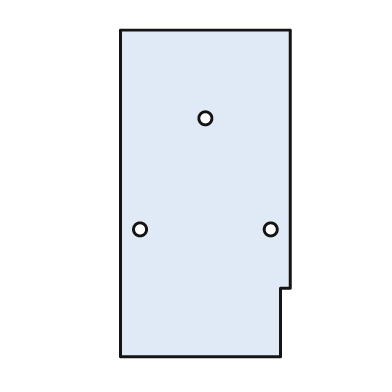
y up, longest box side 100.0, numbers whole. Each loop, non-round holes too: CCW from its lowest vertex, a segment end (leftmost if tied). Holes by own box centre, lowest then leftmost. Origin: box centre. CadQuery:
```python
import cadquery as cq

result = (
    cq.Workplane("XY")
    .moveTo(-26.0, -50.0)
    .lineTo(23.0, -50.0)
    .lineTo(23.0, -29.0)
    .lineTo(26.0, -29.0)
    .lineTo(26.0, 50.0)
    .lineTo(-26.0, 50.0)
    .close()
    .moveTo(-20.0, -11.0)
    .circle(2.0)
    .moveTo(20.0, -11.0)
    .circle(2.0)
    .moveTo(0.0, 23.0)
    .circle(2.0)
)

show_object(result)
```